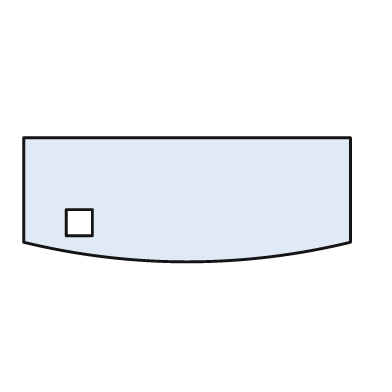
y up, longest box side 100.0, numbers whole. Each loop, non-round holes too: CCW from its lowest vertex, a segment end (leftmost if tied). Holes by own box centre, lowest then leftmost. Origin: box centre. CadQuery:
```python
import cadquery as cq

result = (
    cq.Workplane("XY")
    .moveTo(-50.0, -13.0)
    .threePointArc((0.0, -19.0), (50.0, -13.0))
    .lineTo(50.0, 19.0)
    .lineTo(-50.0, 19.0)
    .close()
    .moveTo(-37.0, -11.0)
    .lineTo(-29.0, -11.0)
    .lineTo(-29.0, -3.0)
    .lineTo(-37.0, -3.0)
    .close()
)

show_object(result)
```